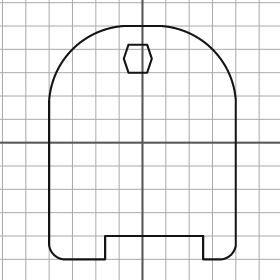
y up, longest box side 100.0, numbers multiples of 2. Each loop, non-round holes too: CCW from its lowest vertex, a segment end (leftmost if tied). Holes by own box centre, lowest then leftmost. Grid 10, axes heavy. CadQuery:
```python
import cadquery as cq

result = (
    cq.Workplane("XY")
    .moveTo(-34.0, -50.0)
    .lineTo(-16.0, -50.0)
    .lineTo(-16.0, -40.0)
    .lineTo(26.0, -40.0)
    .lineTo(26.0, -50.0)
    .lineTo(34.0, -50.0)
    .threePointArc((38.0, -48.0), (40.0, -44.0))
    .lineTo(40.0, 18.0)
    .threePointArc((30.0, 40.0), (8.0, 50.0))
    .lineTo(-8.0, 50.0)
    .threePointArc((-30.0, 40.0), (-40.0, 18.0))
    .lineTo(-40.0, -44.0)
    .threePointArc((-38.0, -48.0), (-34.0, -50.0))
    .close()
    .moveTo(-6.0, 30.0)
    .lineTo(2.0, 30.0)
    .lineTo(4.0, 36.0)
    .lineTo(2.0, 42.0)
    .lineTo(-6.0, 42.0)
    .lineTo(-8.0, 36.0)
    .close()
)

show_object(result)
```